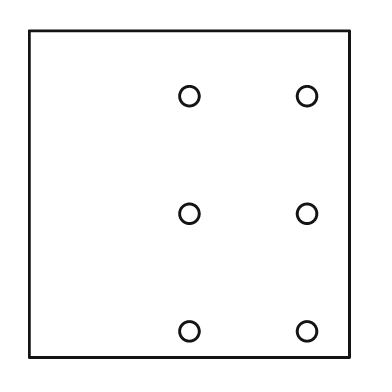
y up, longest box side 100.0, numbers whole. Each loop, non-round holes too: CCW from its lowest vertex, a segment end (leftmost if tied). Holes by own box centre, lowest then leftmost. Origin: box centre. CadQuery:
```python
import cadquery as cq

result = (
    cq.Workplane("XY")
    .moveTo(-49.0, -50.0)
    .lineTo(49.0, -50.0)
    .lineTo(49.0, 50.0)
    .lineTo(-49.0, 50.0)
    .close()
    .moveTo(0.0, -42.0)
    .circle(3.0)
    .moveTo(36.0, -42.0)
    .circle(3.0)
    .moveTo(0.0, -6.0)
    .circle(3.0)
    .moveTo(36.0, -6.0)
    .circle(3.0)
    .moveTo(0.0, 30.0)
    .circle(3.0)
    .moveTo(36.0, 30.0)
    .circle(3.0)
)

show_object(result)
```